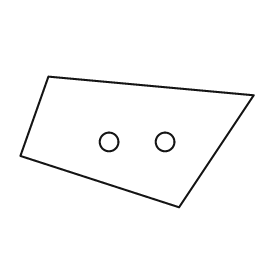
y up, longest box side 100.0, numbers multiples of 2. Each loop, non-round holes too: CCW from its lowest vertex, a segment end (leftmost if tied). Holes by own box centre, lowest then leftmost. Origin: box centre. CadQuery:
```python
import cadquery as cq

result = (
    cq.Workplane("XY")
    .moveTo(18.0, -28.0)
    .lineTo(50.0, 20.0)
    .lineTo(-38.0, 28.0)
    .lineTo(-50.0, -6.0)
    .close()
    .moveTo(-12.0, 0.0)
    .circle(4.0)
    .moveTo(12.0, 0.0)
    .circle(4.0)
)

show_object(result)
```